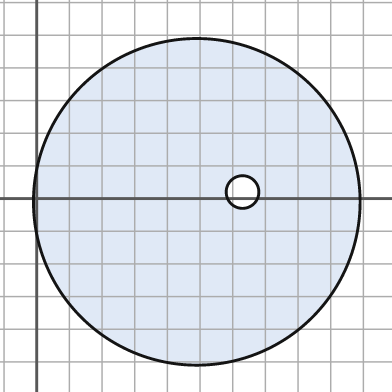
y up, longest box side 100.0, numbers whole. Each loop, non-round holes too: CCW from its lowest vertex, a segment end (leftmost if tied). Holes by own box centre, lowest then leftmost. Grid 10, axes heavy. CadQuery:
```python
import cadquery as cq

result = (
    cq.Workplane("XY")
    .moveTo(49.0, -1.0)
    .circle(50.0)
    .moveTo(63.0, 2.0)
    .circle(5.0)
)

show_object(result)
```